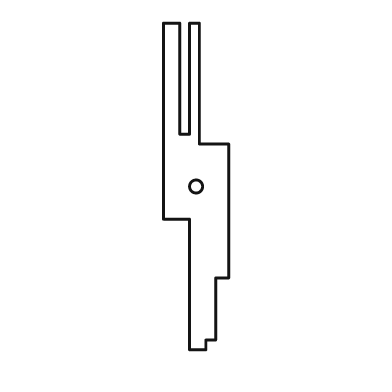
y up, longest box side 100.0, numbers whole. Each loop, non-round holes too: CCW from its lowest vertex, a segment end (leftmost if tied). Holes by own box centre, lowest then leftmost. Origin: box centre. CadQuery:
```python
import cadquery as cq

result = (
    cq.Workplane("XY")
    .moveTo(-2.0, -50.0)
    .lineTo(3.0, -50.0)
    .lineTo(3.0, -47.0)
    .lineTo(6.0, -47.0)
    .lineTo(6.0, -28.0)
    .lineTo(10.0, -28.0)
    .lineTo(10.0, 13.0)
    .lineTo(1.0, 13.0)
    .lineTo(1.0, 50.0)
    .lineTo(-2.0, 50.0)
    .lineTo(-2.0, 16.0)
    .lineTo(-5.0, 16.0)
    .lineTo(-5.0, 50.0)
    .lineTo(-10.0, 50.0)
    .lineTo(-10.0, -10.0)
    .lineTo(-2.0, -10.0)
    .close()
    .moveTo(0.0, 0.0)
    .circle(2.0)
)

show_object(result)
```